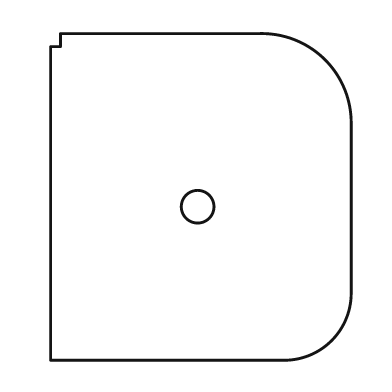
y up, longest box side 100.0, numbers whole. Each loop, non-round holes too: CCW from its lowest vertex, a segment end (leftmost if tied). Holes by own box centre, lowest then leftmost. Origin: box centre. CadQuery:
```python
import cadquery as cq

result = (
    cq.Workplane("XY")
    .moveTo(-46.0, -50.0)
    .lineTo(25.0, -50.0)
    .threePointArc((40.0, -44.0), (46.0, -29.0))
    .lineTo(46.0, 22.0)
    .threePointArc((38.0, 42.0), (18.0, 50.0))
    .lineTo(-43.0, 50.0)
    .lineTo(-43.0, 46.0)
    .lineTo(-46.0, 46.0)
    .close()
    .moveTo(-1.0, -3.0)
    .circle(5.0)
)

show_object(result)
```